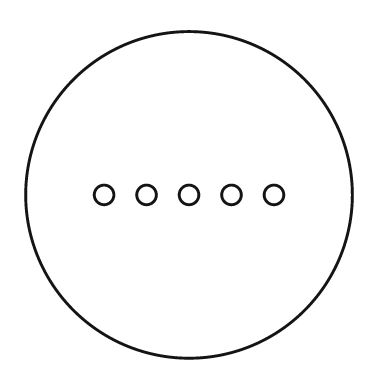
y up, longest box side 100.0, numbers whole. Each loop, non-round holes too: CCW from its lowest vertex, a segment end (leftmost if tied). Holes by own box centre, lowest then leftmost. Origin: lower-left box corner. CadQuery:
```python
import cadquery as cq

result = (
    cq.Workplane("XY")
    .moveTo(50.0, 50.0)
    .circle(50.0)
    .moveTo(24.0, 50.0)
    .circle(3.0)
    .moveTo(37.0, 50.0)
    .circle(3.0)
    .moveTo(50.0, 50.0)
    .circle(3.0)
    .moveTo(63.0, 50.0)
    .circle(3.0)
    .moveTo(76.0, 50.0)
    .circle(3.0)
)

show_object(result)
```